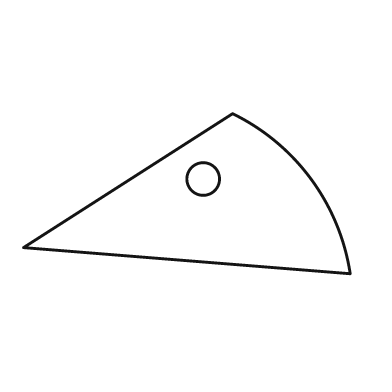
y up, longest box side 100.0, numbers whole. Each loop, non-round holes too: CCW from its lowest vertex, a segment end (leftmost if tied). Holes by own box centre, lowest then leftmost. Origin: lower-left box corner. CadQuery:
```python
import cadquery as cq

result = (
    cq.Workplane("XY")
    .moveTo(100.0, 0.0)
    .threePointArc((88.0, 29.0), (64.0, 49.0))
    .lineTo(0.0, 8.0)
    .close()
    .moveTo(55.0, 29.0)
    .circle(5.0)
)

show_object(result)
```